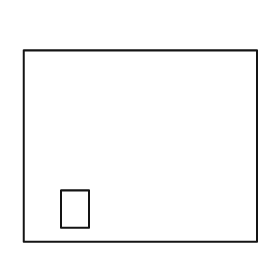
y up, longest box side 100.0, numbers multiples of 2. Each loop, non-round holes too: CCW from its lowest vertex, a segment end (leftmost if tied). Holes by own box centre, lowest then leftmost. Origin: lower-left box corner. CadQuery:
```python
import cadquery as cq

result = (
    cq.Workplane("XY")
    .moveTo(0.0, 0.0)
    .lineTo(100.0, 0.0)
    .lineTo(100.0, 82.0)
    .lineTo(0.0, 82.0)
    .close()
    .moveTo(16.0, 6.0)
    .lineTo(28.0, 6.0)
    .lineTo(28.0, 22.0)
    .lineTo(16.0, 22.0)
    .close()
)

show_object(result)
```